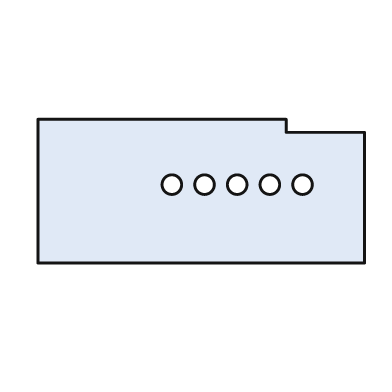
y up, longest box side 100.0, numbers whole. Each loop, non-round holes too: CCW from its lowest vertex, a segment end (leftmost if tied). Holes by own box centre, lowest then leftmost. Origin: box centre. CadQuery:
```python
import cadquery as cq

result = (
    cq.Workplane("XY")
    .moveTo(-50.0, -22.0)
    .lineTo(50.0, -22.0)
    .lineTo(50.0, 18.0)
    .lineTo(26.0, 18.0)
    .lineTo(26.0, 22.0)
    .lineTo(-50.0, 22.0)
    .close()
    .moveTo(-9.0, 2.0)
    .circle(3.0)
    .moveTo(1.0, 2.0)
    .circle(3.0)
    .moveTo(11.0, 2.0)
    .circle(3.0)
    .moveTo(21.0, 2.0)
    .circle(3.0)
    .moveTo(31.0, 2.0)
    .circle(3.0)
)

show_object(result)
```